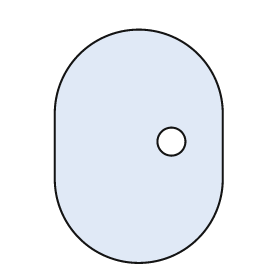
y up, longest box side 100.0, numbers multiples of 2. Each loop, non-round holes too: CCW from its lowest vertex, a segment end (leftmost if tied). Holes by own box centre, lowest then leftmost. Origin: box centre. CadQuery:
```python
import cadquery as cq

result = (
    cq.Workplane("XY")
    .moveTo(-36.0, -14.0)
    .threePointArc((0.0, -50.0), (36.0, -14.0))
    .lineTo(36.0, 14.0)
    .threePointArc((0.0, 50.0), (-36.0, 14.0))
    .close()
    .moveTo(14.0, 2.0)
    .circle(6.0)
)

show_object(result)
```